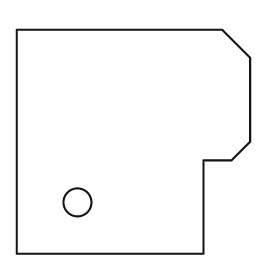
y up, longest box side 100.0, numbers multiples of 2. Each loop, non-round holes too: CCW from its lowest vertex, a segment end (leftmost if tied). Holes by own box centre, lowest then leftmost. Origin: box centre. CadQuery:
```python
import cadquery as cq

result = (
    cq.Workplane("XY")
    .moveTo(-50.0, -48.0)
    .lineTo(30.0, -48.0)
    .lineTo(30.0, -8.0)
    .lineTo(42.0, -8.0)
    .lineTo(50.0, 0.0)
    .lineTo(50.0, 36.0)
    .lineTo(38.0, 48.0)
    .lineTo(-50.0, 48.0)
    .close()
    .moveTo(-24.0, -26.0)
    .circle(6.0)
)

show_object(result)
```